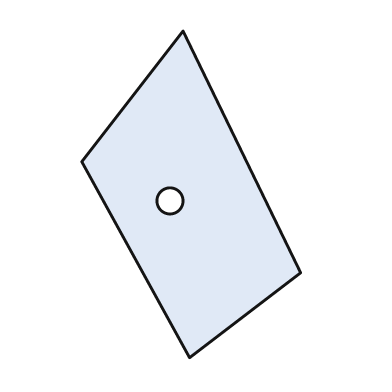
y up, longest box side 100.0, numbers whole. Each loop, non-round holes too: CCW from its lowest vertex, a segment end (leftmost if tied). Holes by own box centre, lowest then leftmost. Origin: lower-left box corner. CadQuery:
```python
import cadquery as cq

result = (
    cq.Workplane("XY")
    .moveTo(33.0, 0.0)
    .lineTo(67.0, 26.0)
    .lineTo(31.0, 100.0)
    .lineTo(0.0, 60.0)
    .close()
    .moveTo(27.0, 48.0)
    .circle(4.0)
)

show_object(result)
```